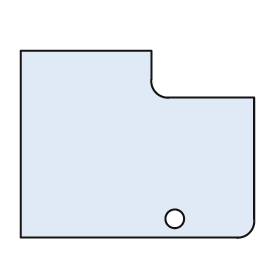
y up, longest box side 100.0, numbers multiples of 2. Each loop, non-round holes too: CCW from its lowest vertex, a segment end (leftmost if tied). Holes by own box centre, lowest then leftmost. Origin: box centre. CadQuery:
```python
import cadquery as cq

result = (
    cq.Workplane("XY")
    .moveTo(-50.0, -40.0)
    .lineTo(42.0, -40.0)
    .threePointArc((48.0, -38.0), (50.0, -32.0))
    .lineTo(50.0, 20.0)
    .lineTo(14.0, 20.0)
    .threePointArc((8.0, 22.0), (6.0, 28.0))
    .lineTo(6.0, 40.0)
    .lineTo(-50.0, 40.0)
    .close()
    .moveTo(16.0, -32.0)
    .circle(4.0)
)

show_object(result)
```